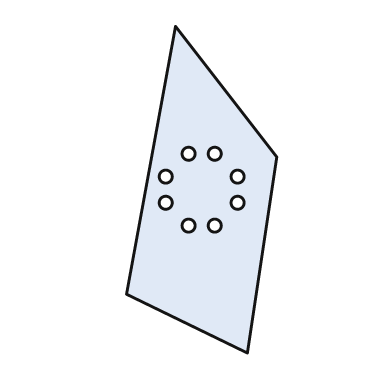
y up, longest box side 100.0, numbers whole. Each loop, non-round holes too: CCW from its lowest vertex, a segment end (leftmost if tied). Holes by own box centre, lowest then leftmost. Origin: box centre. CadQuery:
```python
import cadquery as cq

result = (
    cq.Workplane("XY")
    .moveTo(14.0, -50.0)
    .lineTo(23.0, 10.0)
    .lineTo(-8.0, 50.0)
    .lineTo(-23.0, -32.0)
    .close()
    .moveTo(-4.0, -11.0)
    .circle(2.0)
    .moveTo(4.0, -11.0)
    .circle(2.0)
    .moveTo(-11.0, -4.0)
    .circle(2.0)
    .moveTo(11.0, -4.0)
    .circle(2.0)
    .moveTo(-11.0, 4.0)
    .circle(2.0)
    .moveTo(11.0, 4.0)
    .circle(2.0)
    .moveTo(-4.0, 11.0)
    .circle(2.0)
    .moveTo(4.0, 11.0)
    .circle(2.0)
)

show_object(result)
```